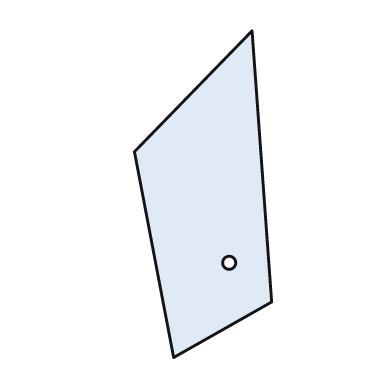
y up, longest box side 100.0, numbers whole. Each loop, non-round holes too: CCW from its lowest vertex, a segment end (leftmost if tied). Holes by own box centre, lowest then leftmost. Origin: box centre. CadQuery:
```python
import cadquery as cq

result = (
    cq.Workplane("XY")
    .moveTo(-9.0, -50.0)
    .lineTo(21.0, -33.0)
    .lineTo(15.0, 50.0)
    .lineTo(-21.0, 13.0)
    .close()
    .moveTo(8.0, -21.0)
    .circle(2.0)
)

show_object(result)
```